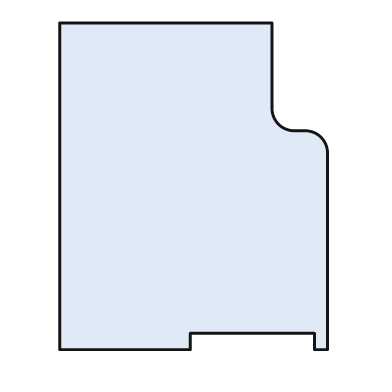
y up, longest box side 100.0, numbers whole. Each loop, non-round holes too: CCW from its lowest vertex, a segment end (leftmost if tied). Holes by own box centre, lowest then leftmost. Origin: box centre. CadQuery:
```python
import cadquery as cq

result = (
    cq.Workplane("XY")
    .moveTo(-41.0, -50.0)
    .lineTo(-1.0, -50.0)
    .lineTo(-1.0, -45.0)
    .lineTo(37.0, -45.0)
    .lineTo(37.0, -50.0)
    .lineTo(41.0, -50.0)
    .lineTo(41.0, 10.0)
    .threePointArc((39.0, 15.0), (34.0, 17.0))
    .lineTo(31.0, 17.0)
    .threePointArc((26.0, 19.0), (24.0, 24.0))
    .lineTo(24.0, 50.0)
    .lineTo(-41.0, 50.0)
    .close()
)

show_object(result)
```